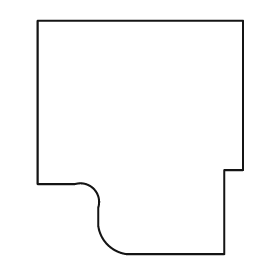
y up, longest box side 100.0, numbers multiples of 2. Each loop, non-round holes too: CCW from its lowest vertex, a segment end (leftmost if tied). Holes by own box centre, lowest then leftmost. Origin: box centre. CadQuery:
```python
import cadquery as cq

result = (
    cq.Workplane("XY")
    .moveTo(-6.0, -50.0)
    .lineTo(36.0, -50.0)
    .lineTo(36.0, -14.0)
    .lineTo(44.0, -14.0)
    .lineTo(44.0, 50.0)
    .lineTo(-44.0, 50.0)
    .lineTo(-44.0, -20.0)
    .lineTo(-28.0, -20.0)
    .threePointArc((-20.0, -22.0), (-18.0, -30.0))
    .lineTo(-18.0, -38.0)
    .threePointArc((-14.0, -46.0), (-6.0, -50.0))
    .close()
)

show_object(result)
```